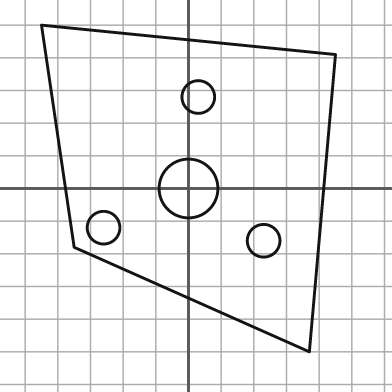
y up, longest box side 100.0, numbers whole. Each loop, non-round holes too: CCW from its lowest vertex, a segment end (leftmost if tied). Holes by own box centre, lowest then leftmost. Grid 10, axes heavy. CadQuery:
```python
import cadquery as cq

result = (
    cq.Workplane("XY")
    .moveTo(37.0, -50.0)
    .lineTo(45.0, 41.0)
    .lineTo(-45.0, 50.0)
    .lineTo(-35.0, -18.0)
    .close()
    .moveTo(23.0, -16.0)
    .circle(5.0)
    .moveTo(-26.0, -12.0)
    .circle(5.0)
    .moveTo(0.0, 0.0)
    .circle(9.0)
    .moveTo(3.0, 28.0)
    .circle(5.0)
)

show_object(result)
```